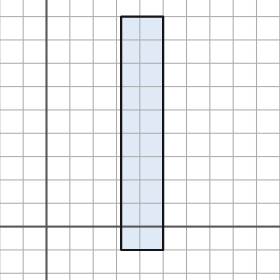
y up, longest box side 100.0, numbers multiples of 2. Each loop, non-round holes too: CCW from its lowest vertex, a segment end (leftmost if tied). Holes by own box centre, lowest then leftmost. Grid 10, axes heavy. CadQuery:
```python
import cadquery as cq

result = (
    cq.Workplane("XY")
    .moveTo(32.0, -10.0)
    .lineTo(50.0, -10.0)
    .lineTo(50.0, 90.0)
    .lineTo(32.0, 90.0)
    .close()
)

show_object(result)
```